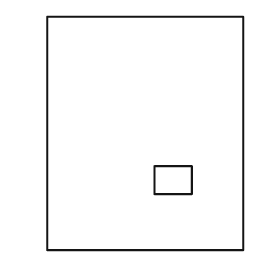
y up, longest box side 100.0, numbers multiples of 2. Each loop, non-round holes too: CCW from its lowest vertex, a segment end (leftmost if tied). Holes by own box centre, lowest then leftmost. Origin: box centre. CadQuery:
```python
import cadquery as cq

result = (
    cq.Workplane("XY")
    .moveTo(-42.0, -50.0)
    .lineTo(42.0, -50.0)
    .lineTo(42.0, 50.0)
    .lineTo(-42.0, 50.0)
    .close()
    .moveTo(4.0, -26.0)
    .lineTo(20.0, -26.0)
    .lineTo(20.0, -14.0)
    .lineTo(4.0, -14.0)
    .close()
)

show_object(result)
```